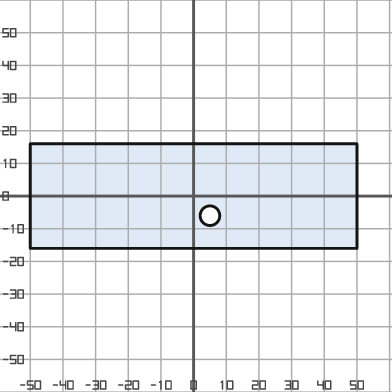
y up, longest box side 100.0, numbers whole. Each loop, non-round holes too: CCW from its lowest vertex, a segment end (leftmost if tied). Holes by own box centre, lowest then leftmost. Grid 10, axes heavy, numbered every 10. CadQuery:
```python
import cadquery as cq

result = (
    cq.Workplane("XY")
    .moveTo(-50.0, -16.0)
    .lineTo(50.0, -16.0)
    .lineTo(50.0, 16.0)
    .lineTo(-50.0, 16.0)
    .close()
    .moveTo(5.0, -6.0)
    .circle(3.0)
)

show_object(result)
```